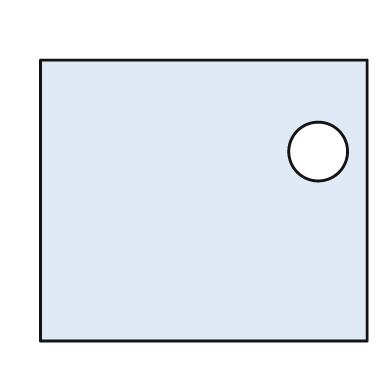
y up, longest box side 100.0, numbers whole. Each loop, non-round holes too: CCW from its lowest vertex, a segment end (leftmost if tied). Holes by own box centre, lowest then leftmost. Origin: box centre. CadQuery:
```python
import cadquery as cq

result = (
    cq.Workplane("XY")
    .moveTo(-50.0, -43.0)
    .lineTo(50.0, -43.0)
    .lineTo(50.0, 43.0)
    .lineTo(-50.0, 43.0)
    .close()
    .moveTo(35.0, 15.0)
    .circle(9.0)
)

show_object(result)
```